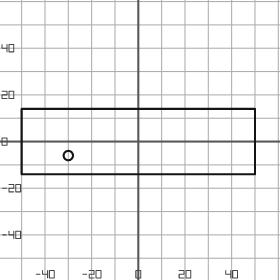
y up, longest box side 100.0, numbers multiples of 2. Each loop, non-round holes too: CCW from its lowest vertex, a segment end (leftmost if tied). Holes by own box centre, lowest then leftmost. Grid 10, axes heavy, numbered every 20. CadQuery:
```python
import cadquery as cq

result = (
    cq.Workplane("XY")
    .moveTo(-50.0, -14.0)
    .lineTo(50.0, -14.0)
    .lineTo(50.0, 14.0)
    .lineTo(-50.0, 14.0)
    .close()
    .moveTo(-30.0, -6.0)
    .circle(2.0)
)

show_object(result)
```